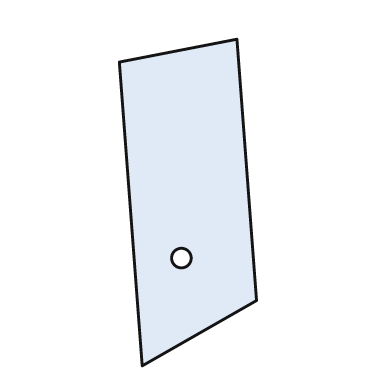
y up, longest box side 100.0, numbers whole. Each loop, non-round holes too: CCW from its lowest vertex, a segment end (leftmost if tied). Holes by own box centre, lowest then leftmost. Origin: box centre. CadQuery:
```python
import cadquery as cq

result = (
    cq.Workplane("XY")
    .moveTo(-14.0, -50.0)
    .lineTo(21.0, -30.0)
    .lineTo(15.0, 50.0)
    .lineTo(-21.0, 43.0)
    .close()
    .moveTo(-2.0, -17.0)
    .circle(3.0)
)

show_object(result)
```